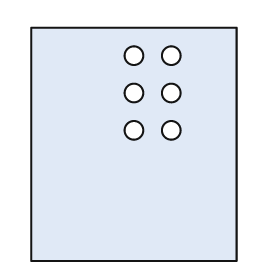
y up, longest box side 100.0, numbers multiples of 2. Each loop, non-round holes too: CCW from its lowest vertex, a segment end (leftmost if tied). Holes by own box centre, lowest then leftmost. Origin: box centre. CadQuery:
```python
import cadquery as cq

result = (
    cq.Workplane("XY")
    .moveTo(-44.0, -50.0)
    .lineTo(44.0, -50.0)
    .lineTo(44.0, 50.0)
    .lineTo(-44.0, 50.0)
    .close()
    .moveTo(0.0, 6.0)
    .circle(4.0)
    .moveTo(16.0, 6.0)
    .circle(4.0)
    .moveTo(0.0, 22.0)
    .circle(4.0)
    .moveTo(16.0, 22.0)
    .circle(4.0)
    .moveTo(0.0, 38.0)
    .circle(4.0)
    .moveTo(16.0, 38.0)
    .circle(4.0)
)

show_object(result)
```